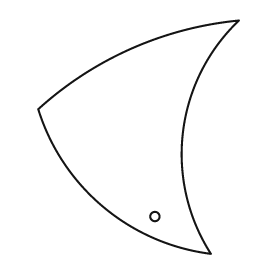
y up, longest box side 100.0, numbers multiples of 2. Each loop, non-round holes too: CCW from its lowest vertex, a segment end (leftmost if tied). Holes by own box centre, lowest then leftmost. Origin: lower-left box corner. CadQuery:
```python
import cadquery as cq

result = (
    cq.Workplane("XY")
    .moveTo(74.0, 0.0)
    .threePointArc((62.0, 52.0), (86.0, 100.0))
    .threePointArc((40.0, 88.0), (0.0, 62.0))
    .threePointArc((28.0, 20.0), (74.0, 0.0))
    .close()
    .moveTo(50.0, 16.0)
    .circle(2.0)
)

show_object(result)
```